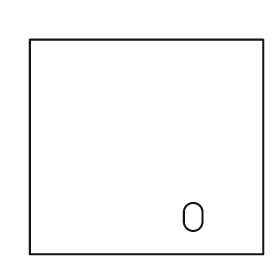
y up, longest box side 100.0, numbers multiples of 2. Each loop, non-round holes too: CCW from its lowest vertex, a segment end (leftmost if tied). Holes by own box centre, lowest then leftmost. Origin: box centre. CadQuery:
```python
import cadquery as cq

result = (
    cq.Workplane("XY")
    .moveTo(-50.0, -46.0)
    .lineTo(50.0, -46.0)
    .lineTo(50.0, 46.0)
    .lineTo(-50.0, 46.0)
    .close()
    .moveTo(16.0, -32.0)
    .threePointArc((20.0, -36.0), (24.0, -32.0))
    .lineTo(24.0, -28.0)
    .threePointArc((20.0, -24.0), (16.0, -28.0))
    .close()
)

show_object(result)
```